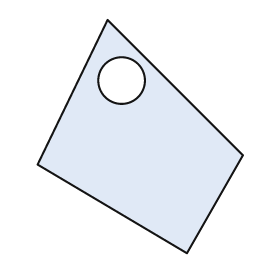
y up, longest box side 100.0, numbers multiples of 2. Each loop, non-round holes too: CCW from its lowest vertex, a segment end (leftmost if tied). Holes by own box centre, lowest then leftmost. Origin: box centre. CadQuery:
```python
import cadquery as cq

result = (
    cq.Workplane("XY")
    .moveTo(20.0, -50.0)
    .lineTo(44.0, -8.0)
    .lineTo(-14.0, 50.0)
    .lineTo(-44.0, -12.0)
    .close()
    .moveTo(-8.0, 24.0)
    .circle(10.0)
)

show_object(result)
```